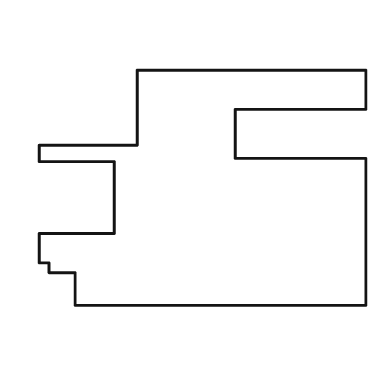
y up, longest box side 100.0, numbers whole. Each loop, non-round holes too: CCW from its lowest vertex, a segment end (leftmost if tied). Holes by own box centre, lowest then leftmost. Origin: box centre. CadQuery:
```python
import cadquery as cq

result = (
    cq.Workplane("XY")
    .moveTo(-39.0, -36.0)
    .lineTo(50.0, -36.0)
    .lineTo(50.0, 9.0)
    .lineTo(10.0, 9.0)
    .lineTo(10.0, 24.0)
    .lineTo(50.0, 24.0)
    .lineTo(50.0, 36.0)
    .lineTo(-20.0, 36.0)
    .lineTo(-20.0, 13.0)
    .lineTo(-50.0, 13.0)
    .lineTo(-50.0, 8.0)
    .lineTo(-27.0, 8.0)
    .lineTo(-27.0, -14.0)
    .lineTo(-50.0, -14.0)
    .lineTo(-50.0, -23.0)
    .lineTo(-47.0, -23.0)
    .lineTo(-47.0, -26.0)
    .lineTo(-39.0, -26.0)
    .close()
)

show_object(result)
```